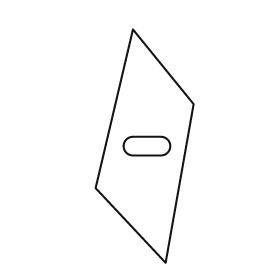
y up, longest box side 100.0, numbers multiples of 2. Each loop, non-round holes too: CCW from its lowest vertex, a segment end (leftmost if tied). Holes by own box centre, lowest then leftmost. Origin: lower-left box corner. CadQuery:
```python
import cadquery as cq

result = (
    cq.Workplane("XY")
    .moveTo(30.0, 0.0)
    .lineTo(42.0, 68.0)
    .lineTo(16.0, 100.0)
    .lineTo(0.0, 32.0)
    .close()
    .moveTo(16.0, 46.0)
    .lineTo(28.0, 46.0)
    .threePointArc((32.0, 50.0), (28.0, 54.0))
    .lineTo(16.0, 54.0)
    .threePointArc((12.0, 50.0), (16.0, 46.0))
    .close()
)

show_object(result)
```